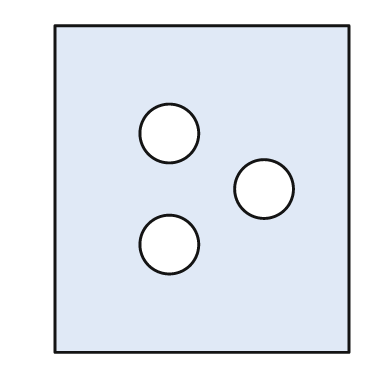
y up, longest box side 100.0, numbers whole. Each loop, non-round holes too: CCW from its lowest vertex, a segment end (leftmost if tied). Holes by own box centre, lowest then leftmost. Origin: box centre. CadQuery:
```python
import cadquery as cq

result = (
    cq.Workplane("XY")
    .moveTo(-45.0, -50.0)
    .lineTo(45.0, -50.0)
    .lineTo(45.0, 50.0)
    .lineTo(-45.0, 50.0)
    .close()
    .moveTo(-10.0, -17.0)
    .circle(9.0)
    .moveTo(19.0, 0.0)
    .circle(9.0)
    .moveTo(-10.0, 17.0)
    .circle(9.0)
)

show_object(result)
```